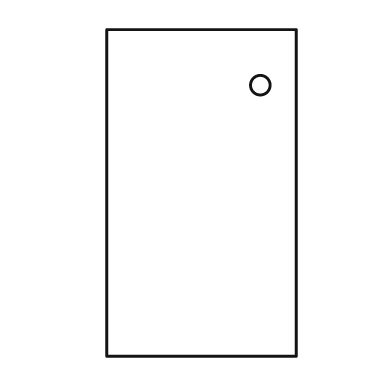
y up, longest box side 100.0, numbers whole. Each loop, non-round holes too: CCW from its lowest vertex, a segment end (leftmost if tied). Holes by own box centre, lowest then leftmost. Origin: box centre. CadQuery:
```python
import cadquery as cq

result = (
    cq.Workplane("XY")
    .moveTo(-29.0, -50.0)
    .lineTo(29.0, -50.0)
    .lineTo(29.0, 50.0)
    .lineTo(-29.0, 50.0)
    .close()
    .moveTo(18.0, 33.0)
    .circle(3.0)
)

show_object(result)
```